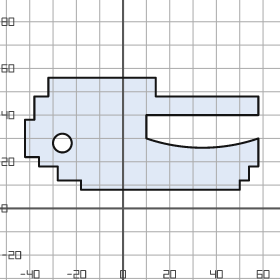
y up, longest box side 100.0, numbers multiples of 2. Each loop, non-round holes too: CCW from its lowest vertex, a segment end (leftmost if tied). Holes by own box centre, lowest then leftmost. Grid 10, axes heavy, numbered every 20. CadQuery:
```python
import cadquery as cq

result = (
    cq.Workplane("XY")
    .moveTo(-18.0, 8.0)
    .lineTo(50.0, 8.0)
    .lineTo(50.0, 12.0)
    .lineTo(54.0, 12.0)
    .lineTo(54.0, 18.0)
    .lineTo(58.0, 18.0)
    .lineTo(58.0, 30.0)
    .threePointArc((34.0, 26.0), (10.0, 30.0))
    .lineTo(10.0, 40.0)
    .lineTo(58.0, 40.0)
    .lineTo(58.0, 48.0)
    .lineTo(14.0, 48.0)
    .lineTo(14.0, 56.0)
    .lineTo(-32.0, 56.0)
    .lineTo(-32.0, 48.0)
    .lineTo(-38.0, 48.0)
    .lineTo(-38.0, 38.0)
    .lineTo(-42.0, 38.0)
    .lineTo(-42.0, 22.0)
    .lineTo(-36.0, 22.0)
    .lineTo(-36.0, 18.0)
    .lineTo(-28.0, 18.0)
    .lineTo(-28.0, 12.0)
    .lineTo(-18.0, 12.0)
    .close()
    .moveTo(-26.0, 28.0)
    .circle(4.0)
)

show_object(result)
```